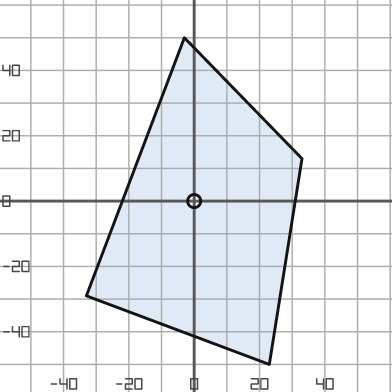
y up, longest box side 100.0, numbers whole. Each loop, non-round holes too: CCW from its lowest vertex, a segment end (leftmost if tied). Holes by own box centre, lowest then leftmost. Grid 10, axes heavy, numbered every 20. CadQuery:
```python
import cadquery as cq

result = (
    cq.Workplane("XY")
    .moveTo(23.0, -50.0)
    .lineTo(33.0, 13.0)
    .lineTo(-3.0, 50.0)
    .lineTo(-33.0, -29.0)
    .close()
    .moveTo(0.0, 0.0)
    .circle(2.0)
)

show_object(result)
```